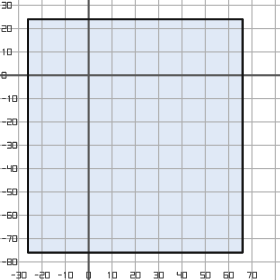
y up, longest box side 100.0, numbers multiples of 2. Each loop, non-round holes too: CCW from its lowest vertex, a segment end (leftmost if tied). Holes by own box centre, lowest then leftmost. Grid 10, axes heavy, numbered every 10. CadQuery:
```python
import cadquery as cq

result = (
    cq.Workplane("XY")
    .moveTo(-26.0, -76.0)
    .lineTo(66.0, -76.0)
    .lineTo(66.0, 24.0)
    .lineTo(-26.0, 24.0)
    .close()
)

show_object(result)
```